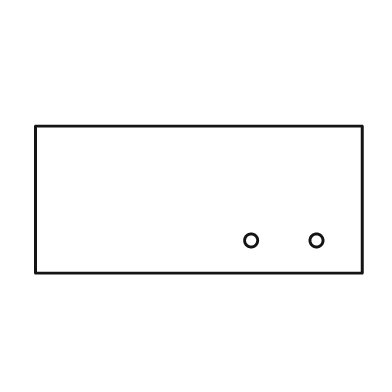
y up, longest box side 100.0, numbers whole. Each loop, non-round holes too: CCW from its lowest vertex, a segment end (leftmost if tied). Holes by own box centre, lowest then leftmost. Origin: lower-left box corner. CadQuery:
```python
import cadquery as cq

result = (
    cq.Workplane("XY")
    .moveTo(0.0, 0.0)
    .lineTo(100.0, 0.0)
    .lineTo(100.0, 45.0)
    .lineTo(0.0, 45.0)
    .close()
    .moveTo(66.0, 10.0)
    .circle(2.0)
    .moveTo(86.0, 10.0)
    .circle(2.0)
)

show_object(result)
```